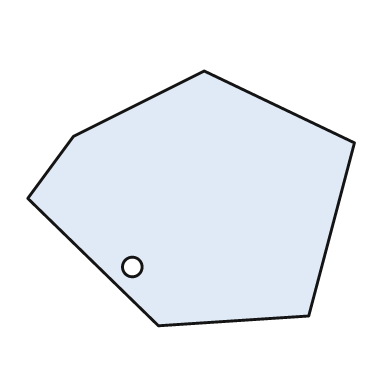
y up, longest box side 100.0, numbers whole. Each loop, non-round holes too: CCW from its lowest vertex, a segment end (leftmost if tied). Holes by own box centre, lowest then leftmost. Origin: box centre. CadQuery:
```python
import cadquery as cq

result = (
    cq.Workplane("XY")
    .moveTo(-10.0, -39.0)
    .lineTo(36.0, -36.0)
    .lineTo(50.0, 17.0)
    .lineTo(4.0, 39.0)
    .lineTo(-36.0, 19.0)
    .lineTo(-50.0, 0.0)
    .close()
    .moveTo(-18.0, -21.0)
    .circle(3.0)
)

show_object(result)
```